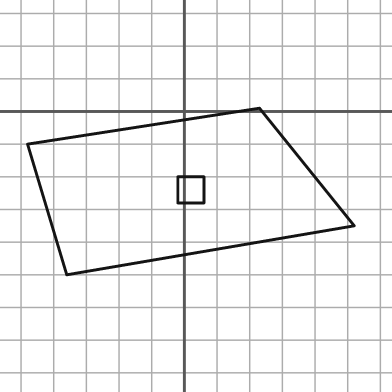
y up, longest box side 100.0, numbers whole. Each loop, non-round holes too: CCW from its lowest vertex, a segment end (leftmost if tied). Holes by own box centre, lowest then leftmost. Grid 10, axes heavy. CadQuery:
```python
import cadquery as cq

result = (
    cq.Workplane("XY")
    .moveTo(-36.0, -50.0)
    .lineTo(52.0, -35.0)
    .lineTo(23.0, 1.0)
    .lineTo(-48.0, -10.0)
    .close()
    .moveTo(-2.0, -28.0)
    .lineTo(6.0, -28.0)
    .lineTo(6.0, -20.0)
    .lineTo(-2.0, -20.0)
    .close()
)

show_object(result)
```